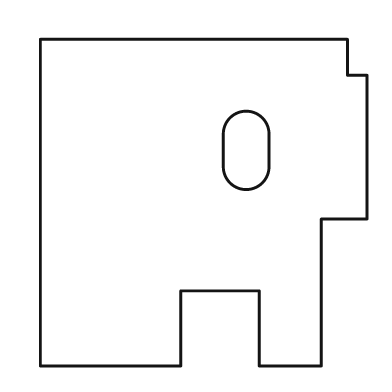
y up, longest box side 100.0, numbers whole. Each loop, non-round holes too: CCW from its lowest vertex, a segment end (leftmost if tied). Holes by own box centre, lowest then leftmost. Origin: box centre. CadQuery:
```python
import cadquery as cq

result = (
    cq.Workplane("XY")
    .moveTo(-50.0, -50.0)
    .lineTo(-7.0, -50.0)
    .lineTo(-7.0, -27.0)
    .lineTo(17.0, -27.0)
    .lineTo(17.0, -50.0)
    .lineTo(36.0, -50.0)
    .lineTo(36.0, -5.0)
    .lineTo(50.0, -5.0)
    .lineTo(50.0, 39.0)
    .lineTo(44.0, 39.0)
    .lineTo(44.0, 50.0)
    .lineTo(-50.0, 50.0)
    .close()
    .moveTo(6.0, 11.0)
    .threePointArc((13.0, 4.0), (20.0, 11.0))
    .lineTo(20.0, 21.0)
    .threePointArc((13.0, 28.0), (6.0, 21.0))
    .close()
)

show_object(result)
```